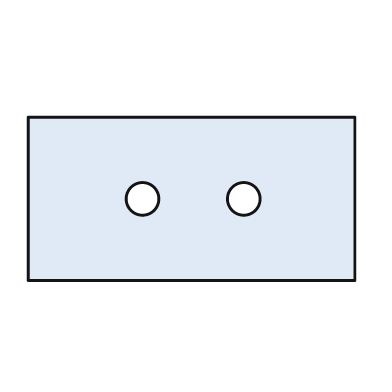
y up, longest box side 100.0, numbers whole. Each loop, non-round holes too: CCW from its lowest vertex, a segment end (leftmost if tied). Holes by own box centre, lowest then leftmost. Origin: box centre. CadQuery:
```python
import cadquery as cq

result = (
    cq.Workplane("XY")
    .moveTo(-50.0, -25.0)
    .lineTo(50.0, -25.0)
    .lineTo(50.0, 25.0)
    .lineTo(-50.0, 25.0)
    .close()
    .moveTo(-15.0, 0.0)
    .circle(5.0)
    .moveTo(16.0, 0.0)
    .circle(5.0)
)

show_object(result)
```